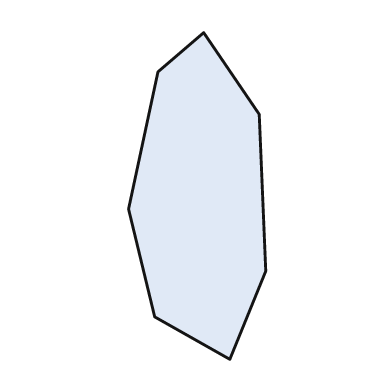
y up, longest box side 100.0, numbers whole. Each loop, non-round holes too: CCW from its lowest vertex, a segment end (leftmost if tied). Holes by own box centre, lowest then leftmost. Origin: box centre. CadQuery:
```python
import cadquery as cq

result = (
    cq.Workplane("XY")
    .moveTo(10.0, -50.0)
    .lineTo(21.0, -23.0)
    .lineTo(19.0, 25.0)
    .lineTo(2.0, 50.0)
    .lineTo(-12.0, 38.0)
    .lineTo(-21.0, -4.0)
    .lineTo(-13.0, -37.0)
    .close()
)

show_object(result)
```